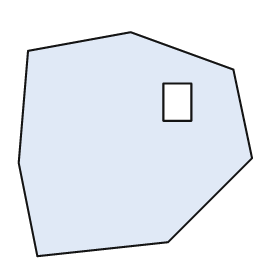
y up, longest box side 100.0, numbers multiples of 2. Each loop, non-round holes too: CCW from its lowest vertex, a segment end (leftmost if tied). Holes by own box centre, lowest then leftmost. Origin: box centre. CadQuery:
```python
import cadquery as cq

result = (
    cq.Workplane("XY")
    .moveTo(-42.0, -48.0)
    .lineTo(14.0, -42.0)
    .lineTo(50.0, -6.0)
    .lineTo(42.0, 32.0)
    .lineTo(-2.0, 48.0)
    .lineTo(-46.0, 40.0)
    .lineTo(-50.0, -8.0)
    .close()
    .moveTo(12.0, 10.0)
    .lineTo(24.0, 10.0)
    .lineTo(24.0, 26.0)
    .lineTo(12.0, 26.0)
    .close()
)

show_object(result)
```